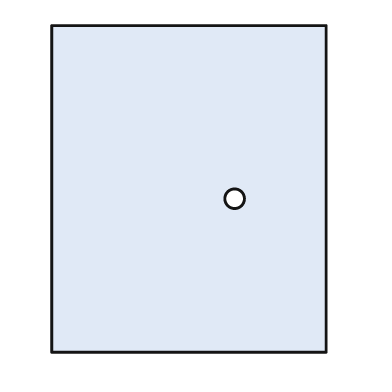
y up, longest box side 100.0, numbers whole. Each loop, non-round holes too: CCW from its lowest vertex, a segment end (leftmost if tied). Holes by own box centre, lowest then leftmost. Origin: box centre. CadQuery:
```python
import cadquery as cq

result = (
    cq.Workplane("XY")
    .moveTo(-42.0, -50.0)
    .lineTo(42.0, -50.0)
    .lineTo(42.0, 50.0)
    .lineTo(-42.0, 50.0)
    .close()
    .moveTo(14.0, -3.0)
    .circle(3.0)
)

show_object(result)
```